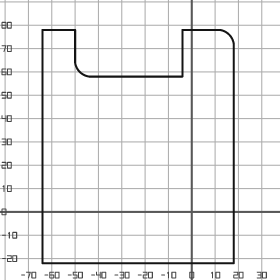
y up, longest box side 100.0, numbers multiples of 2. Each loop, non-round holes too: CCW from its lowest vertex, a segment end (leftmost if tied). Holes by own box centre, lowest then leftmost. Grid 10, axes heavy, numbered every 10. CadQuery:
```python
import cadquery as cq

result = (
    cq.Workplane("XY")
    .moveTo(-64.0, -22.0)
    .lineTo(18.0, -22.0)
    .lineTo(18.0, 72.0)
    .threePointArc((16.0, 76.0), (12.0, 78.0))
    .lineTo(-4.0, 78.0)
    .lineTo(-4.0, 58.0)
    .lineTo(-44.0, 58.0)
    .threePointArc((-48.0, 60.0), (-50.0, 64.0))
    .lineTo(-50.0, 78.0)
    .lineTo(-64.0, 78.0)
    .close()
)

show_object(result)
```